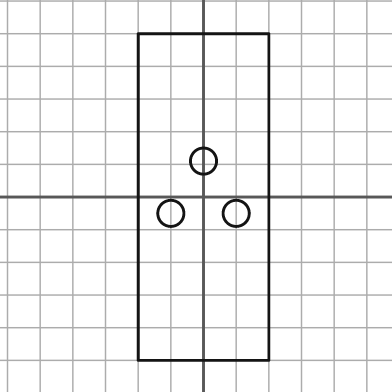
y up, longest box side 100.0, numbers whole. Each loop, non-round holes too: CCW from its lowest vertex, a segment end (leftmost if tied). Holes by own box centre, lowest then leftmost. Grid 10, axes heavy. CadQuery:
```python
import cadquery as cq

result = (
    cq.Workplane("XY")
    .moveTo(-20.0, -50.0)
    .lineTo(20.0, -50.0)
    .lineTo(20.0, 50.0)
    .lineTo(-20.0, 50.0)
    .close()
    .moveTo(-10.0, -5.0)
    .circle(4.0)
    .moveTo(10.0, -5.0)
    .circle(4.0)
    .moveTo(0.0, 11.0)
    .circle(4.0)
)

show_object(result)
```